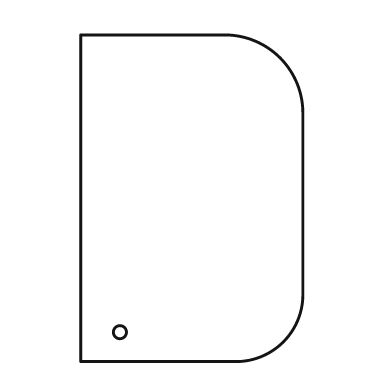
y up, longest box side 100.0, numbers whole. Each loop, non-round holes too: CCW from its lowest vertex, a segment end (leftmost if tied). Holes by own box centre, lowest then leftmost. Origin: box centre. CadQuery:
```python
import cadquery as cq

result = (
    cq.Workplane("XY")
    .moveTo(-34.0, -50.0)
    .lineTo(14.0, -50.0)
    .threePointArc((28.0, -44.0), (34.0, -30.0))
    .lineTo(34.0, 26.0)
    .threePointArc((27.0, 43.0), (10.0, 50.0))
    .lineTo(-34.0, 50.0)
    .close()
    .moveTo(-22.0, -41.0)
    .circle(2.0)
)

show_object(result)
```